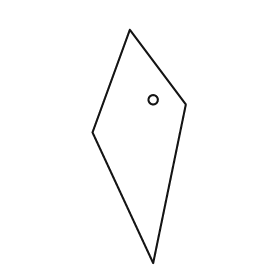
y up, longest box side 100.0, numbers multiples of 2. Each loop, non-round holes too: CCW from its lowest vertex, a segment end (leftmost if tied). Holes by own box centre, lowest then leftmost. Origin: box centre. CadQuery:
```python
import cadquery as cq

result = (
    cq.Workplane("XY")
    .moveTo(6.0, -50.0)
    .lineTo(20.0, 18.0)
    .lineTo(-4.0, 50.0)
    .lineTo(-20.0, 6.0)
    .close()
    .moveTo(6.0, 20.0)
    .circle(2.0)
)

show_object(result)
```